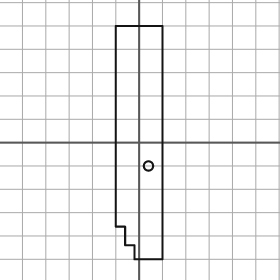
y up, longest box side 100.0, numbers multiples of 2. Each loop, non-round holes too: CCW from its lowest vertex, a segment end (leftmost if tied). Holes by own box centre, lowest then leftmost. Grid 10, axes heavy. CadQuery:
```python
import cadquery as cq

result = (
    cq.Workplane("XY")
    .moveTo(-2.0, -50.0)
    .lineTo(10.0, -50.0)
    .lineTo(10.0, 50.0)
    .lineTo(-10.0, 50.0)
    .lineTo(-10.0, -36.0)
    .lineTo(-6.0, -36.0)
    .lineTo(-6.0, -44.0)
    .lineTo(-2.0, -44.0)
    .close()
    .moveTo(4.0, -10.0)
    .circle(2.0)
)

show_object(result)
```